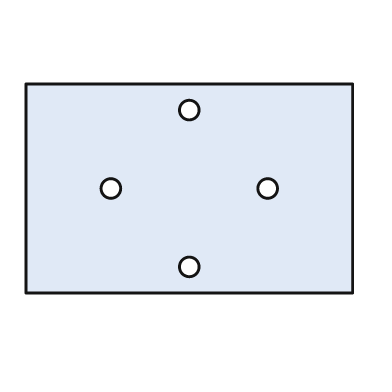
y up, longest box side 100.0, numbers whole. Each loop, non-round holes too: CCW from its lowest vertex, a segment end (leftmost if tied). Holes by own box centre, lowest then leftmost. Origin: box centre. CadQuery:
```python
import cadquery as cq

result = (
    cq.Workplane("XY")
    .moveTo(-50.0, -32.0)
    .lineTo(50.0, -32.0)
    .lineTo(50.0, 32.0)
    .lineTo(-50.0, 32.0)
    .close()
    .moveTo(0.0, -24.0)
    .circle(3.0)
    .moveTo(-24.0, 0.0)
    .circle(3.0)
    .moveTo(24.0, 0.0)
    .circle(3.0)
    .moveTo(0.0, 24.0)
    .circle(3.0)
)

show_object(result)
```